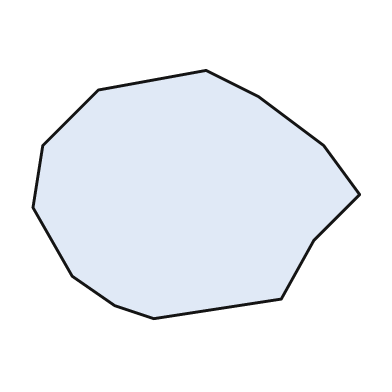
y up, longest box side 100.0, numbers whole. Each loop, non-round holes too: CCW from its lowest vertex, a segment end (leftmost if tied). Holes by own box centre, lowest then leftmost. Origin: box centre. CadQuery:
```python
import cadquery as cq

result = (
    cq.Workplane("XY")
    .moveTo(-13.0, -38.0)
    .lineTo(26.0, -32.0)
    .lineTo(36.0, -14.0)
    .lineTo(50.0, 0.0)
    .lineTo(39.0, 15.0)
    .lineTo(19.0, 30.0)
    .lineTo(3.0, 38.0)
    .lineTo(-30.0, 32.0)
    .lineTo(-47.0, 15.0)
    .lineTo(-50.0, -4.0)
    .lineTo(-38.0, -25.0)
    .lineTo(-25.0, -34.0)
    .close()
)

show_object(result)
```